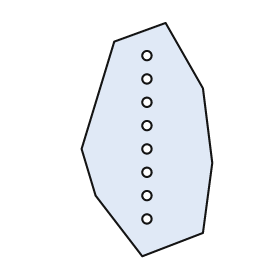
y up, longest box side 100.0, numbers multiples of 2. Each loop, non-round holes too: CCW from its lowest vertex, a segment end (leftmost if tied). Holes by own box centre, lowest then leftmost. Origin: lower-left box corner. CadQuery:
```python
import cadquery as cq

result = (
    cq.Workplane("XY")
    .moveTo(26.0, 0.0)
    .lineTo(52.0, 10.0)
    .lineTo(56.0, 40.0)
    .lineTo(52.0, 72.0)
    .lineTo(36.0, 100.0)
    .lineTo(14.0, 92.0)
    .lineTo(0.0, 46.0)
    .lineTo(6.0, 26.0)
    .close()
    .moveTo(28.0, 16.0)
    .circle(2.0)
    .moveTo(28.0, 26.0)
    .circle(2.0)
    .moveTo(28.0, 36.0)
    .circle(2.0)
    .moveTo(28.0, 46.0)
    .circle(2.0)
    .moveTo(28.0, 56.0)
    .circle(2.0)
    .moveTo(28.0, 66.0)
    .circle(2.0)
    .moveTo(28.0, 76.0)
    .circle(2.0)
    .moveTo(28.0, 86.0)
    .circle(2.0)
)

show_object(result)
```